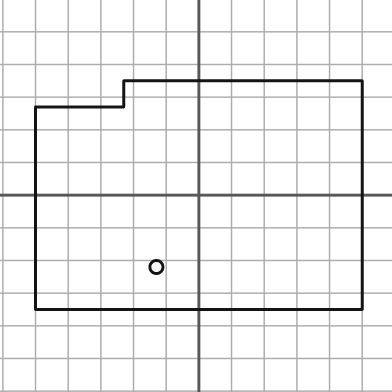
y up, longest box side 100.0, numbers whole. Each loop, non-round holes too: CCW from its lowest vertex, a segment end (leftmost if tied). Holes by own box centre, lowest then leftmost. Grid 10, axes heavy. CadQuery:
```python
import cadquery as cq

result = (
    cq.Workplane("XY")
    .moveTo(-50.0, -35.0)
    .lineTo(50.0, -35.0)
    .lineTo(50.0, 35.0)
    .lineTo(-23.0, 35.0)
    .lineTo(-23.0, 27.0)
    .lineTo(-50.0, 27.0)
    .close()
    .moveTo(-13.0, -22.0)
    .circle(2.0)
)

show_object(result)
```